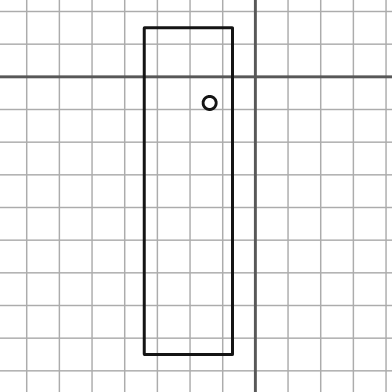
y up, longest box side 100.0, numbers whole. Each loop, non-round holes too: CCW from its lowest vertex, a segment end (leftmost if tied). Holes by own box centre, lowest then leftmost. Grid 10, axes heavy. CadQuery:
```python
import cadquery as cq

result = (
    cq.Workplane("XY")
    .moveTo(-34.0, -85.0)
    .lineTo(-7.0, -85.0)
    .lineTo(-7.0, 15.0)
    .lineTo(-34.0, 15.0)
    .close()
    .moveTo(-14.0, -8.0)
    .circle(2.0)
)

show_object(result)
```